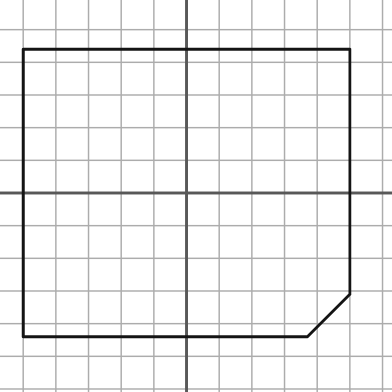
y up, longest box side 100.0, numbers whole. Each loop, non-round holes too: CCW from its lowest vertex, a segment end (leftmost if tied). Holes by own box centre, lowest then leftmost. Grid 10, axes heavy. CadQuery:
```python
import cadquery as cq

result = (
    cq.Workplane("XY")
    .moveTo(-50.0, -44.0)
    .lineTo(37.0, -44.0)
    .lineTo(50.0, -31.0)
    .lineTo(50.0, 44.0)
    .lineTo(-50.0, 44.0)
    .close()
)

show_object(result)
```